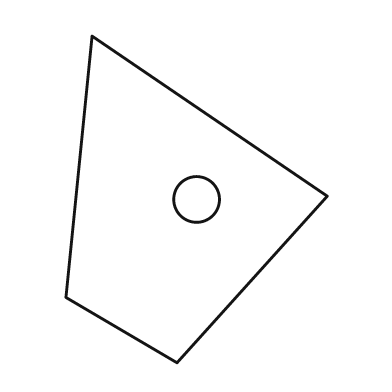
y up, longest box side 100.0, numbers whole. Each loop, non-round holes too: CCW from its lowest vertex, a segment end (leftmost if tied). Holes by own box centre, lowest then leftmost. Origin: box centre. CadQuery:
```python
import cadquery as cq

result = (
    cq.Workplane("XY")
    .moveTo(-6.0, -50.0)
    .lineTo(40.0, 1.0)
    .lineTo(-32.0, 50.0)
    .lineTo(-40.0, -30.0)
    .close()
    .moveTo(0.0, 0.0)
    .circle(7.0)
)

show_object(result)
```